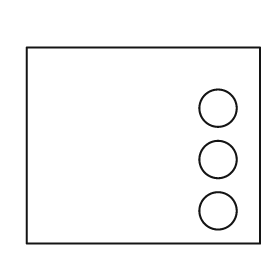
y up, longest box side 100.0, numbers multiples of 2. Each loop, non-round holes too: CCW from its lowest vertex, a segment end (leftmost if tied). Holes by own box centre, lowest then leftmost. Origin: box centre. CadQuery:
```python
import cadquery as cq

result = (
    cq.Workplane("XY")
    .moveTo(-50.0, -42.0)
    .lineTo(50.0, -42.0)
    .lineTo(50.0, 42.0)
    .lineTo(-50.0, 42.0)
    .close()
    .moveTo(32.0, -28.0)
    .circle(8.0)
    .moveTo(32.0, -6.0)
    .circle(8.0)
    .moveTo(32.0, 16.0)
    .circle(8.0)
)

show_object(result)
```